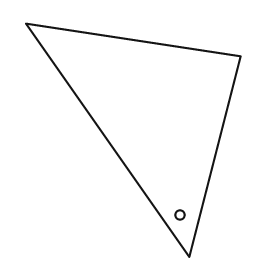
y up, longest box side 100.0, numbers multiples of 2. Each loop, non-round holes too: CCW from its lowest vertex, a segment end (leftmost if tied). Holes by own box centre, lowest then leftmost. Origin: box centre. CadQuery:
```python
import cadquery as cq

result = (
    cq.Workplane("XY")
    .moveTo(24.0, -50.0)
    .lineTo(46.0, 36.0)
    .lineTo(-46.0, 50.0)
    .close()
    .moveTo(20.0, -32.0)
    .circle(2.0)
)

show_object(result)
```